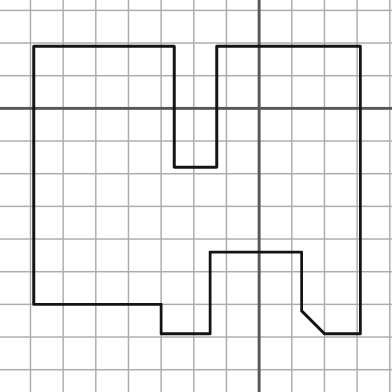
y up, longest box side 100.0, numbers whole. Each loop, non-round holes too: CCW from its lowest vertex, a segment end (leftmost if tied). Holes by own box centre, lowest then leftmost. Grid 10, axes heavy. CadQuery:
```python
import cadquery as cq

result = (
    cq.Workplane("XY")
    .moveTo(-30.0, -69.0)
    .lineTo(-15.0, -69.0)
    .lineTo(-15.0, -44.0)
    .lineTo(13.0, -44.0)
    .lineTo(13.0, -62.0)
    .lineTo(20.0, -69.0)
    .lineTo(31.0, -69.0)
    .lineTo(31.0, 19.0)
    .lineTo(-13.0, 19.0)
    .lineTo(-13.0, -18.0)
    .lineTo(-26.0, -18.0)
    .lineTo(-26.0, 19.0)
    .lineTo(-69.0, 19.0)
    .lineTo(-69.0, -60.0)
    .lineTo(-30.0, -60.0)
    .close()
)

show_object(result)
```